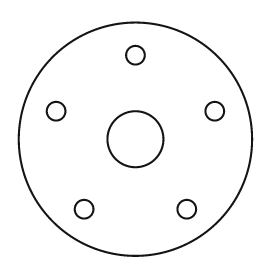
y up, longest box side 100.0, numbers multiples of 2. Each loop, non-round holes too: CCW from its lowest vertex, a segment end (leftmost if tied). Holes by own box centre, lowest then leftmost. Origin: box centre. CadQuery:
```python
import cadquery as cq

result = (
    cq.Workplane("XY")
    .moveTo(0.0, 0.0)
    .circle(50.0)
    .moveTo(-22.0, -30.0)
    .circle(4.0)
    .moveTo(22.0, -30.0)
    .circle(4.0)
    .moveTo(0.0, 0.0)
    .circle(12.0)
    .moveTo(-34.0, 12.0)
    .circle(4.0)
    .moveTo(34.0, 12.0)
    .circle(4.0)
    .moveTo(0.0, 36.0)
    .circle(4.0)
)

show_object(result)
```